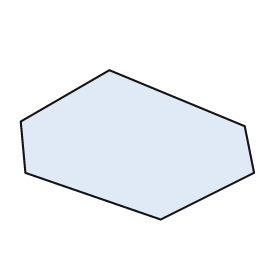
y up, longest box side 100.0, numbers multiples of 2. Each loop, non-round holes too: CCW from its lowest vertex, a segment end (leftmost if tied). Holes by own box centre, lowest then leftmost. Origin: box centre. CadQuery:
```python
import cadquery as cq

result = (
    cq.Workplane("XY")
    .moveTo(10.0, -32.0)
    .lineTo(50.0, -12.0)
    .lineTo(46.0, 8.0)
    .lineTo(-12.0, 32.0)
    .lineTo(-50.0, 10.0)
    .lineTo(-48.0, -12.0)
    .close()
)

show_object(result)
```